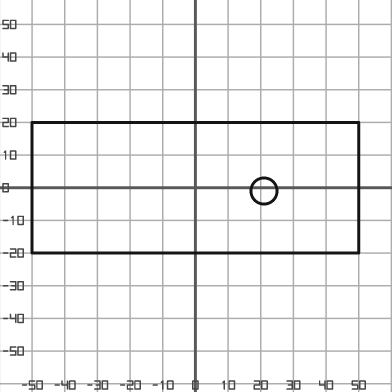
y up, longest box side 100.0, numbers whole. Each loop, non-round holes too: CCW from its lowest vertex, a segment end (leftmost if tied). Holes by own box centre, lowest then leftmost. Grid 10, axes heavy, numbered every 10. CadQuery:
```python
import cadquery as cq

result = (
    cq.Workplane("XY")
    .moveTo(-50.0, -20.0)
    .lineTo(50.0, -20.0)
    .lineTo(50.0, 20.0)
    .lineTo(-50.0, 20.0)
    .close()
    .moveTo(21.0, -1.0)
    .circle(4.0)
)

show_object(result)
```